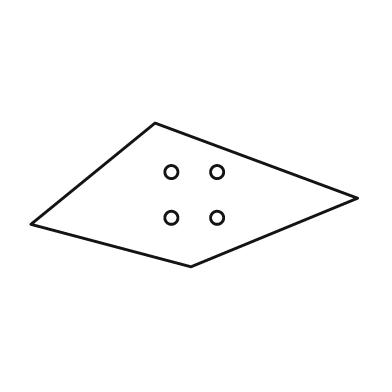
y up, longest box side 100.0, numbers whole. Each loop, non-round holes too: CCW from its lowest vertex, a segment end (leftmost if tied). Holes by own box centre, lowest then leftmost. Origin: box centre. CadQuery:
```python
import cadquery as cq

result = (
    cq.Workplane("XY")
    .moveTo(-1.0, -22.0)
    .lineTo(50.0, -1.0)
    .lineTo(-12.0, 22.0)
    .lineTo(-50.0, -9.0)
    .close()
    .moveTo(-7.0, -7.0)
    .circle(2.0)
    .moveTo(7.0, -7.0)
    .circle(2.0)
    .moveTo(-7.0, 7.0)
    .circle(2.0)
    .moveTo(7.0, 7.0)
    .circle(2.0)
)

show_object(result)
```